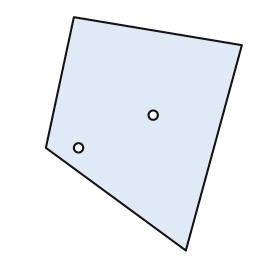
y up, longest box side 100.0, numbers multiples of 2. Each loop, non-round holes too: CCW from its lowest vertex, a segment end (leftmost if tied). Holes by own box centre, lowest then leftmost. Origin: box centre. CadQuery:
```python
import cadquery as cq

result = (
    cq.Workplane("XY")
    .moveTo(18.0, -50.0)
    .lineTo(42.0, 38.0)
    .lineTo(-30.0, 50.0)
    .lineTo(-42.0, -6.0)
    .close()
    .moveTo(-28.0, -6.0)
    .circle(2.0)
    .moveTo(4.0, 8.0)
    .circle(2.0)
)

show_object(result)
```